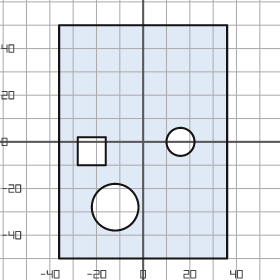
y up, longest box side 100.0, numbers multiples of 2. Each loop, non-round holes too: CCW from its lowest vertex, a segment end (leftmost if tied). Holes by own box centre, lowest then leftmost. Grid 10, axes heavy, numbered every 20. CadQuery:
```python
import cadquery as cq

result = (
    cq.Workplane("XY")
    .moveTo(-36.0, -50.0)
    .lineTo(36.0, -50.0)
    .lineTo(36.0, 50.0)
    .lineTo(-36.0, 50.0)
    .close()
    .moveTo(-12.0, -28.0)
    .circle(10.0)
    .moveTo(-28.0, -10.0)
    .lineTo(-16.0, -10.0)
    .lineTo(-16.0, 2.0)
    .lineTo(-28.0, 2.0)
    .close()
    .moveTo(16.0, 0.0)
    .circle(6.0)
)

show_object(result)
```